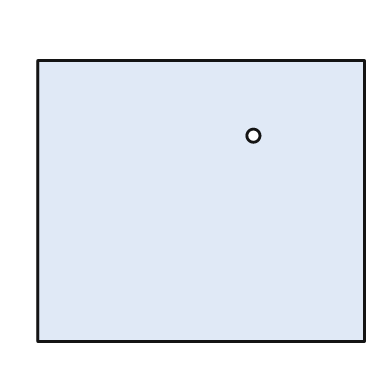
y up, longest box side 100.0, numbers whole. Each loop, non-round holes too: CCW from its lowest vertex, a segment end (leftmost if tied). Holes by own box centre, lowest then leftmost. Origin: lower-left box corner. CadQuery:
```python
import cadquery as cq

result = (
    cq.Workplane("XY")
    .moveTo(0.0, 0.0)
    .lineTo(100.0, 0.0)
    .lineTo(100.0, 86.0)
    .lineTo(0.0, 86.0)
    .close()
    .moveTo(66.0, 63.0)
    .circle(2.0)
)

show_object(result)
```